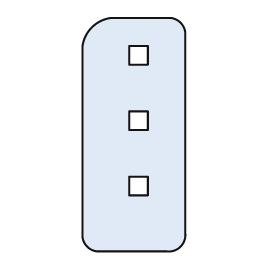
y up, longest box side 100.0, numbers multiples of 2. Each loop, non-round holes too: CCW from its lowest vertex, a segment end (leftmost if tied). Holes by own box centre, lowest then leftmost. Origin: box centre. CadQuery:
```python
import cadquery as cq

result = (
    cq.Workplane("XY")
    .moveTo(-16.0, -50.0)
    .lineTo(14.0, -50.0)
    .threePointArc((20.0, -48.0), (22.0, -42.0))
    .lineTo(22.0, 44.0)
    .threePointArc((20.0, 48.0), (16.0, 50.0))
    .lineTo(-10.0, 50.0)
    .threePointArc((-18.0, 46.0), (-22.0, 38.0))
    .lineTo(-22.0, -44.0)
    .threePointArc((-20.0, -48.0), (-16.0, -50.0))
    .close()
    .moveTo(-2.0, -26.0)
    .lineTo(6.0, -26.0)
    .lineTo(6.0, -18.0)
    .lineTo(-2.0, -18.0)
    .close()
    .moveTo(-2.0, 2.0)
    .lineTo(6.0, 2.0)
    .lineTo(6.0, 10.0)
    .lineTo(-2.0, 10.0)
    .close()
    .moveTo(-2.0, 30.0)
    .lineTo(6.0, 30.0)
    .lineTo(6.0, 38.0)
    .lineTo(-2.0, 38.0)
    .close()
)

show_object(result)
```